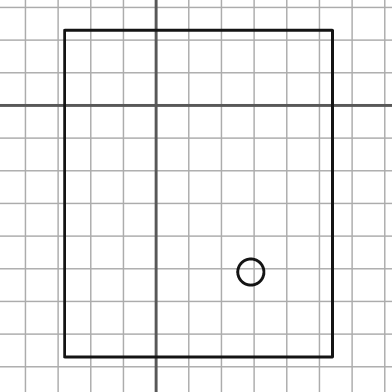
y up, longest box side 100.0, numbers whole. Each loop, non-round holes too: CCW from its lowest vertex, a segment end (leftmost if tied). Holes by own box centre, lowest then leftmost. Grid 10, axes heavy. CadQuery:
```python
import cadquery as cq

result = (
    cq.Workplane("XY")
    .moveTo(-28.0, -77.0)
    .lineTo(54.0, -77.0)
    .lineTo(54.0, 23.0)
    .lineTo(-28.0, 23.0)
    .close()
    .moveTo(29.0, -51.0)
    .circle(4.0)
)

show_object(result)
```